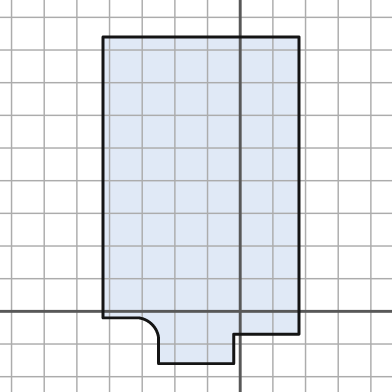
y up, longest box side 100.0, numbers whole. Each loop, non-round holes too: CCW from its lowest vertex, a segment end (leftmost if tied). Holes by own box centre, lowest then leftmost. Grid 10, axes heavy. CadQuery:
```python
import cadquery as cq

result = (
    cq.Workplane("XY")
    .moveTo(-25.0, -16.0)
    .lineTo(-2.0, -16.0)
    .lineTo(-2.0, -7.0)
    .lineTo(18.0, -7.0)
    .lineTo(18.0, 84.0)
    .lineTo(-42.0, 84.0)
    .lineTo(-42.0, -2.0)
    .lineTo(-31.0, -2.0)
    .threePointArc((-27.0, -4.0), (-25.0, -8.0))
    .close()
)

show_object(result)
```